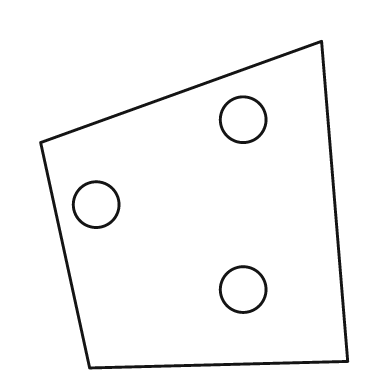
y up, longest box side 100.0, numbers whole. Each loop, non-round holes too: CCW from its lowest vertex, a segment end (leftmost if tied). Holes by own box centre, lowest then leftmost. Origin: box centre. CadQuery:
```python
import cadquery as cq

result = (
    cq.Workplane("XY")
    .moveTo(-32.0, -50.0)
    .lineTo(47.0, -48.0)
    .lineTo(39.0, 50.0)
    .lineTo(-47.0, 19.0)
    .close()
    .moveTo(15.0, -26.0)
    .circle(7.0)
    .moveTo(-30.0, 0.0)
    .circle(7.0)
    .moveTo(15.0, 26.0)
    .circle(7.0)
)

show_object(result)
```